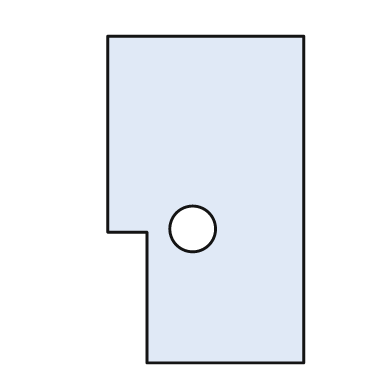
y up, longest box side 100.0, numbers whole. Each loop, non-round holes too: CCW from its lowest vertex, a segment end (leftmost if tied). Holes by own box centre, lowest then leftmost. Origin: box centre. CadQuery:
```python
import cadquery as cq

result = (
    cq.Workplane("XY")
    .moveTo(-18.0, -50.0)
    .lineTo(30.0, -50.0)
    .lineTo(30.0, 50.0)
    .lineTo(-30.0, 50.0)
    .lineTo(-30.0, -10.0)
    .lineTo(-18.0, -10.0)
    .close()
    .moveTo(-4.0, -9.0)
    .circle(7.0)
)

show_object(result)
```